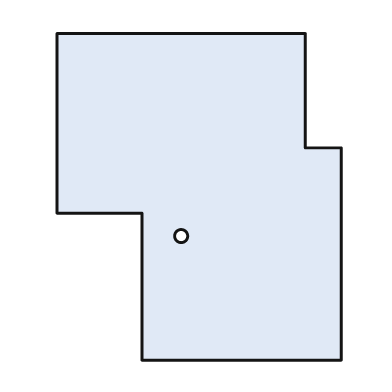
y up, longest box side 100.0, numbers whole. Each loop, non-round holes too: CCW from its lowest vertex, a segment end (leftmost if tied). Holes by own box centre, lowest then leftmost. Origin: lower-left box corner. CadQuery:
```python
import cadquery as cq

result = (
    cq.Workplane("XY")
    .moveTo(26.0, 0.0)
    .lineTo(87.0, 0.0)
    .lineTo(87.0, 65.0)
    .lineTo(76.0, 65.0)
    .lineTo(76.0, 100.0)
    .lineTo(0.0, 100.0)
    .lineTo(0.0, 45.0)
    .lineTo(26.0, 45.0)
    .close()
    .moveTo(38.0, 38.0)
    .circle(2.0)
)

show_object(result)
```